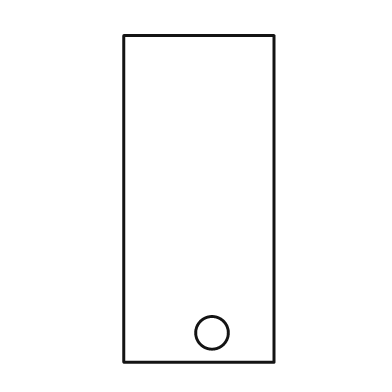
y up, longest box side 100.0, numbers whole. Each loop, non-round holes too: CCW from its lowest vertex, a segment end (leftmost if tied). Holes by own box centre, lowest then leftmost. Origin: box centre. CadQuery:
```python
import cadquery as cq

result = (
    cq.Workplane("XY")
    .moveTo(-23.0, -50.0)
    .lineTo(23.0, -50.0)
    .lineTo(23.0, 50.0)
    .lineTo(-23.0, 50.0)
    .close()
    .moveTo(4.0, -41.0)
    .circle(5.0)
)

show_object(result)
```